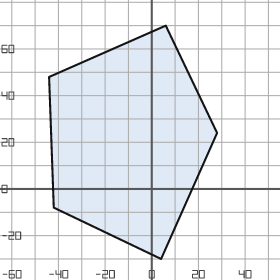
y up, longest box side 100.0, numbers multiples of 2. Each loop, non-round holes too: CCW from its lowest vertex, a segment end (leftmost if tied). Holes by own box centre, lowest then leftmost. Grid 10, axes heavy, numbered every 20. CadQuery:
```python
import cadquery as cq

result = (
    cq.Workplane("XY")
    .moveTo(4.0, -30.0)
    .lineTo(28.0, 24.0)
    .lineTo(6.0, 70.0)
    .lineTo(-44.0, 48.0)
    .lineTo(-42.0, -8.0)
    .close()
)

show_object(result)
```